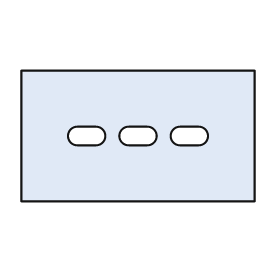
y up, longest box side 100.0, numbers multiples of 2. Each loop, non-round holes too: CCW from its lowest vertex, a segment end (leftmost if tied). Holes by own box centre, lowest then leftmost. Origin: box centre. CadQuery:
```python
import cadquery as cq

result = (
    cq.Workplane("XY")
    .moveTo(-50.0, -28.0)
    .lineTo(50.0, -28.0)
    .lineTo(50.0, 28.0)
    .lineTo(-50.0, 28.0)
    .close()
    .moveTo(-26.0, -4.0)
    .lineTo(-18.0, -4.0)
    .threePointArc((-14.0, 0.0), (-18.0, 4.0))
    .lineTo(-26.0, 4.0)
    .threePointArc((-30.0, 0.0), (-26.0, -4.0))
    .close()
    .moveTo(-4.0, -4.0)
    .lineTo(4.0, -4.0)
    .threePointArc((8.0, 0.0), (4.0, 4.0))
    .lineTo(-4.0, 4.0)
    .threePointArc((-8.0, 0.0), (-4.0, -4.0))
    .close()
    .moveTo(18.0, -4.0)
    .lineTo(26.0, -4.0)
    .threePointArc((30.0, 0.0), (26.0, 4.0))
    .lineTo(18.0, 4.0)
    .threePointArc((14.0, 0.0), (18.0, -4.0))
    .close()
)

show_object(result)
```